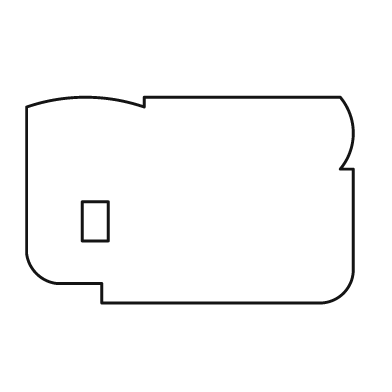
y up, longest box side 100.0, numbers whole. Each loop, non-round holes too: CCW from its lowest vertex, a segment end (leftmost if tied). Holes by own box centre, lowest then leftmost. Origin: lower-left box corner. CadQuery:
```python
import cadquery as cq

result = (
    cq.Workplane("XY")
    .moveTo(23.0, 0.0)
    .lineTo(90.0, 0.0)
    .threePointArc((97.0, 3.0), (100.0, 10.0))
    .lineTo(100.0, 41.0)
    .lineTo(96.0, 41.0)
    .threePointArc((100.0, 52.0), (96.0, 63.0))
    .lineTo(36.0, 63.0)
    .lineTo(36.0, 60.0)
    .threePointArc((18.0, 63.0), (0.0, 60.0))
    .lineTo(0.0, 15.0)
    .threePointArc((3.0, 9.0), (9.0, 6.0))
    .lineTo(23.0, 6.0)
    .close()
    .moveTo(17.0, 19.0)
    .lineTo(25.0, 19.0)
    .lineTo(25.0, 31.0)
    .lineTo(17.0, 31.0)
    .close()
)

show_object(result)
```